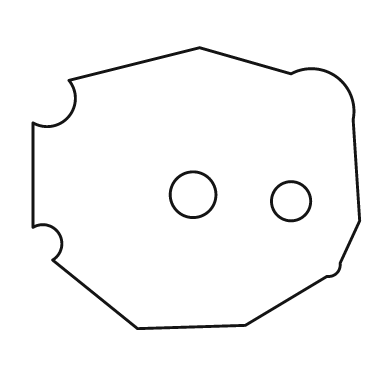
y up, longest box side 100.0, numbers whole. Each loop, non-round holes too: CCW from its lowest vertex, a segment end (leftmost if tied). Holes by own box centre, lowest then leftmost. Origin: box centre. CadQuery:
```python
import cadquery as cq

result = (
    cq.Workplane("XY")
    .moveTo(-18.0, -43.0)
    .lineTo(15.0, -42.0)
    .lineTo(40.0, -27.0)
    .threePointArc((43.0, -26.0), (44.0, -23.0))
    .lineTo(50.0, -10.0)
    .lineTo(48.0, 21.0)
    .threePointArc((43.0, 34.0), (29.0, 35.0))
    .lineTo(1.0, 43.0)
    .lineTo(-39.0, 33.0)
    .threePointArc((-39.0, 22.0), (-50.0, 20.0))
    .lineTo(-50.0, -12.0)
    .threePointArc((-42.0, -14.0), (-44.0, -22.0))
    .close()
    .moveTo(29.0, -4.0)
    .circle(6.0)
    .moveTo(-1.0, -2.0)
    .circle(7.0)
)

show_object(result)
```